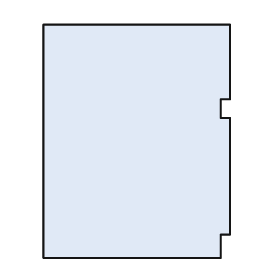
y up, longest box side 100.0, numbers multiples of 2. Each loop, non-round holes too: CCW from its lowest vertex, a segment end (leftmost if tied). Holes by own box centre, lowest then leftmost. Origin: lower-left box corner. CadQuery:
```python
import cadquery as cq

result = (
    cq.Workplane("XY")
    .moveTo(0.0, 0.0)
    .lineTo(76.0, 0.0)
    .lineTo(76.0, 10.0)
    .lineTo(80.0, 10.0)
    .lineTo(80.0, 60.0)
    .lineTo(76.0, 60.0)
    .lineTo(76.0, 68.0)
    .lineTo(80.0, 68.0)
    .lineTo(80.0, 100.0)
    .lineTo(0.0, 100.0)
    .close()
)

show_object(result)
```